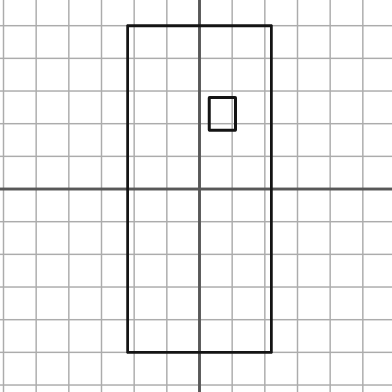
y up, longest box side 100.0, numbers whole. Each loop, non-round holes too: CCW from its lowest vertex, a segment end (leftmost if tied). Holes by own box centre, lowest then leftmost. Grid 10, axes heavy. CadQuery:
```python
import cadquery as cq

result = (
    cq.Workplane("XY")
    .moveTo(-22.0, -50.0)
    .lineTo(22.0, -50.0)
    .lineTo(22.0, 50.0)
    .lineTo(-22.0, 50.0)
    .close()
    .moveTo(3.0, 18.0)
    .lineTo(11.0, 18.0)
    .lineTo(11.0, 28.0)
    .lineTo(3.0, 28.0)
    .close()
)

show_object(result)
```